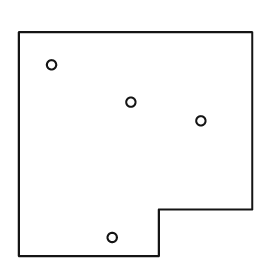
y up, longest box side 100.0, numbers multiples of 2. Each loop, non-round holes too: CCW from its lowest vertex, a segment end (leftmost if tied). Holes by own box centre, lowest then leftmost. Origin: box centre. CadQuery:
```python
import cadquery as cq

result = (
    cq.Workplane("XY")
    .moveTo(-50.0, -48.0)
    .lineTo(10.0, -48.0)
    .lineTo(10.0, -28.0)
    .lineTo(50.0, -28.0)
    .lineTo(50.0, 48.0)
    .lineTo(-50.0, 48.0)
    .close()
    .moveTo(-10.0, -40.0)
    .circle(2.0)
    .moveTo(28.0, 10.0)
    .circle(2.0)
    .moveTo(-2.0, 18.0)
    .circle(2.0)
    .moveTo(-36.0, 34.0)
    .circle(2.0)
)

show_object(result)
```